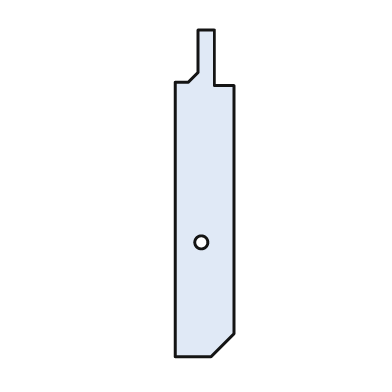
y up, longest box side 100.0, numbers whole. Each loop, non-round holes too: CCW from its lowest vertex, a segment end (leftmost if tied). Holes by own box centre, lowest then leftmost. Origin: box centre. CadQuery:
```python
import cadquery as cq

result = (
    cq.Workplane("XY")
    .moveTo(-9.0, -50.0)
    .lineTo(2.0, -50.0)
    .lineTo(9.0, -43.0)
    .lineTo(9.0, 33.0)
    .lineTo(3.0, 33.0)
    .lineTo(3.0, 50.0)
    .lineTo(-2.0, 50.0)
    .lineTo(-2.0, 37.0)
    .lineTo(-5.0, 34.0)
    .lineTo(-9.0, 34.0)
    .close()
    .moveTo(-1.0, -15.0)
    .circle(2.0)
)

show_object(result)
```